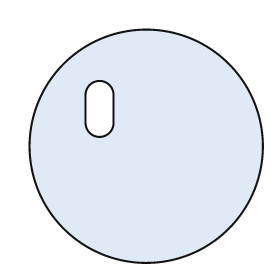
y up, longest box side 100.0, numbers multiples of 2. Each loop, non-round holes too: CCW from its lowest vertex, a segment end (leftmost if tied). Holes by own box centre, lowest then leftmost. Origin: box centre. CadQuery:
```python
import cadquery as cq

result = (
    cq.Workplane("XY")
    .moveTo(0.0, 0.0)
    .circle(50.0)
    .moveTo(-26.0, 10.0)
    .threePointArc((-20.0, 4.0), (-14.0, 10.0))
    .lineTo(-14.0, 22.0)
    .threePointArc((-20.0, 28.0), (-26.0, 22.0))
    .close()
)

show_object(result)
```